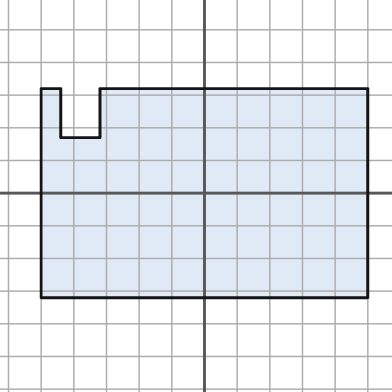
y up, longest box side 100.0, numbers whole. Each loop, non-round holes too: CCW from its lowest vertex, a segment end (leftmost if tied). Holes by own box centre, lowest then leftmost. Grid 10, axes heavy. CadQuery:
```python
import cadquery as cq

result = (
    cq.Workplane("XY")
    .moveTo(-50.0, -32.0)
    .lineTo(50.0, -32.0)
    .lineTo(50.0, 32.0)
    .lineTo(-32.0, 32.0)
    .lineTo(-32.0, 17.0)
    .lineTo(-44.0, 17.0)
    .lineTo(-44.0, 32.0)
    .lineTo(-50.0, 32.0)
    .close()
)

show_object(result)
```